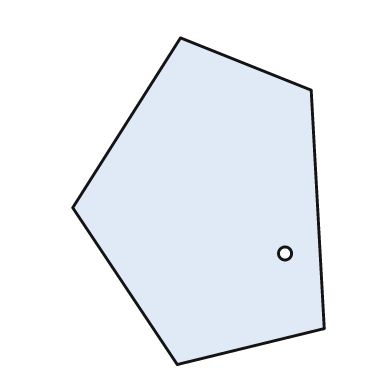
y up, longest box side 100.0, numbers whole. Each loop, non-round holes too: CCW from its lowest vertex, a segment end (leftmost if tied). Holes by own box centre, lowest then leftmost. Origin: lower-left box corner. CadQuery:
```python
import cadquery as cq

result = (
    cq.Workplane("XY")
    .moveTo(32.0, 0.0)
    .lineTo(77.0, 11.0)
    .lineTo(73.0, 84.0)
    .lineTo(33.0, 100.0)
    .lineTo(0.0, 48.0)
    .close()
    .moveTo(65.0, 34.0)
    .circle(2.0)
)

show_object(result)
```